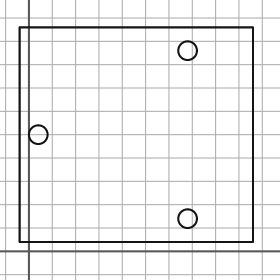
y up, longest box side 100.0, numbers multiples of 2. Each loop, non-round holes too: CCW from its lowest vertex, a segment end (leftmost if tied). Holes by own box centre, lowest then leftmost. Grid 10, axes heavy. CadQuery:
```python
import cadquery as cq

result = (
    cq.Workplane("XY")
    .moveTo(-4.0, 4.0)
    .lineTo(96.0, 4.0)
    .lineTo(96.0, 96.0)
    .lineTo(-4.0, 96.0)
    .close()
    .moveTo(68.0, 14.0)
    .circle(4.0)
    .moveTo(4.0, 50.0)
    .circle(4.0)
    .moveTo(68.0, 86.0)
    .circle(4.0)
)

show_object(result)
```